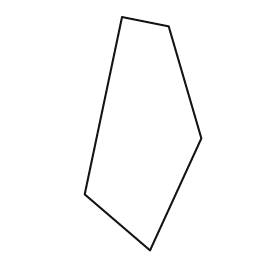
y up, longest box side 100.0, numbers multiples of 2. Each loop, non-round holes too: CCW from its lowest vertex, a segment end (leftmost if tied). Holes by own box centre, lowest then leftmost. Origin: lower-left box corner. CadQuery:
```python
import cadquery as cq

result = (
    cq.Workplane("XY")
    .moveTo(28.0, 0.0)
    .lineTo(50.0, 48.0)
    .lineTo(36.0, 96.0)
    .lineTo(16.0, 100.0)
    .lineTo(0.0, 24.0)
    .close()
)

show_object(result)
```